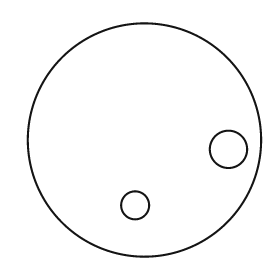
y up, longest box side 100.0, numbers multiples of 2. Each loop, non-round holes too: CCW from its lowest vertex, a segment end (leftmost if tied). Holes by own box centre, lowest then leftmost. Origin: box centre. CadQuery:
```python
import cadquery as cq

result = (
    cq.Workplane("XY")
    .moveTo(0.0, 0.0)
    .circle(50.0)
    .moveTo(-4.0, -28.0)
    .circle(6.0)
    .moveTo(36.0, -4.0)
    .circle(8.0)
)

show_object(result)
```